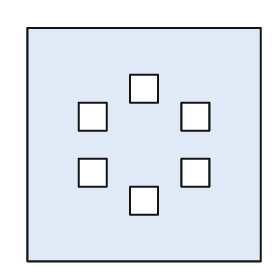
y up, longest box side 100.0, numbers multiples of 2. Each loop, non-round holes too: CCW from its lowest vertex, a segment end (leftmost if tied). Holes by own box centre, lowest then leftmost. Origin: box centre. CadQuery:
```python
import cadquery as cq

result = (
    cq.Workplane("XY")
    .moveTo(-50.0, -50.0)
    .lineTo(50.0, -50.0)
    .lineTo(50.0, 50.0)
    .lineTo(-50.0, 50.0)
    .close()
    .moveTo(-6.0, -30.0)
    .lineTo(6.0, -30.0)
    .lineTo(6.0, -18.0)
    .lineTo(-6.0, -18.0)
    .close()
    .moveTo(-28.0, -18.0)
    .lineTo(-16.0, -18.0)
    .lineTo(-16.0, -6.0)
    .lineTo(-28.0, -6.0)
    .close()
    .moveTo(16.0, -18.0)
    .lineTo(28.0, -18.0)
    .lineTo(28.0, -6.0)
    .lineTo(16.0, -6.0)
    .close()
    .moveTo(-28.0, 6.0)
    .lineTo(-16.0, 6.0)
    .lineTo(-16.0, 18.0)
    .lineTo(-28.0, 18.0)
    .close()
    .moveTo(16.0, 6.0)
    .lineTo(28.0, 6.0)
    .lineTo(28.0, 18.0)
    .lineTo(16.0, 18.0)
    .close()
    .moveTo(-6.0, 18.0)
    .lineTo(6.0, 18.0)
    .lineTo(6.0, 30.0)
    .lineTo(-6.0, 30.0)
    .close()
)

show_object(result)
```